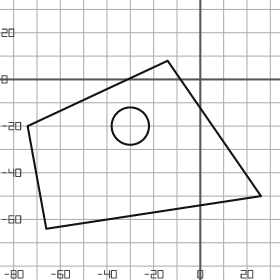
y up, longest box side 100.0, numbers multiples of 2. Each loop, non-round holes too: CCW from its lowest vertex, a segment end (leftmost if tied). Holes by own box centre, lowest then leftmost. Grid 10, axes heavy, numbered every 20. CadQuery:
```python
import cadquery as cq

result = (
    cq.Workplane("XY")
    .moveTo(-66.0, -64.0)
    .lineTo(26.0, -50.0)
    .lineTo(-14.0, 8.0)
    .lineTo(-74.0, -20.0)
    .close()
    .moveTo(-30.0, -20.0)
    .circle(8.0)
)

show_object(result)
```